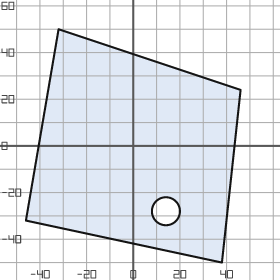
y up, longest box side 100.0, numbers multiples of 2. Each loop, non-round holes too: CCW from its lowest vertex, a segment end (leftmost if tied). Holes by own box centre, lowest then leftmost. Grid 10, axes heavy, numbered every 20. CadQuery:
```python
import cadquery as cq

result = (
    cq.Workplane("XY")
    .moveTo(38.0, -50.0)
    .lineTo(46.0, 24.0)
    .lineTo(-32.0, 50.0)
    .lineTo(-46.0, -32.0)
    .close()
    .moveTo(14.0, -28.0)
    .circle(6.0)
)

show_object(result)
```